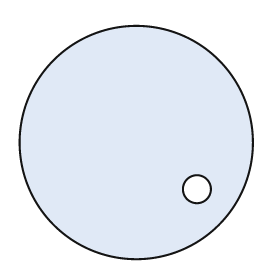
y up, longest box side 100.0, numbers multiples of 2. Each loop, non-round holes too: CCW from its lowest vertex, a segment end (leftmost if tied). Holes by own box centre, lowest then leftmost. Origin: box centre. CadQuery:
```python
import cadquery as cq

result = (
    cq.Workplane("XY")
    .moveTo(0.0, 0.0)
    .circle(50.0)
    .moveTo(26.0, -20.0)
    .circle(6.0)
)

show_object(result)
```